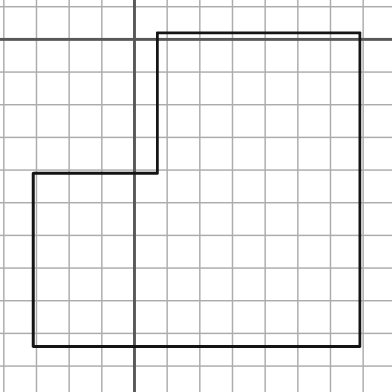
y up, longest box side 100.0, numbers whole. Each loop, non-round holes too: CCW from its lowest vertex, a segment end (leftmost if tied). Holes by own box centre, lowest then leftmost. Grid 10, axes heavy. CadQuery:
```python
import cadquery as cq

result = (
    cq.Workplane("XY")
    .moveTo(-31.0, -94.0)
    .lineTo(69.0, -94.0)
    .lineTo(69.0, 2.0)
    .lineTo(7.0, 2.0)
    .lineTo(7.0, -41.0)
    .lineTo(-31.0, -41.0)
    .close()
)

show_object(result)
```